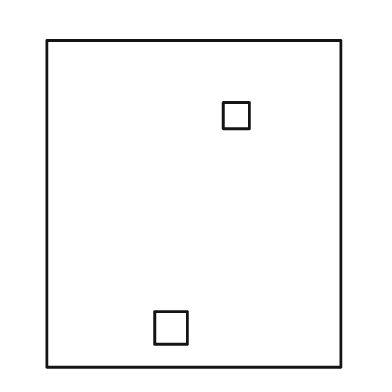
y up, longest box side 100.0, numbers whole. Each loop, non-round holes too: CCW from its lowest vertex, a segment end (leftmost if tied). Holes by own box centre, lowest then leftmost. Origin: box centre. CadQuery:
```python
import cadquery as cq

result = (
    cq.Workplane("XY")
    .moveTo(-45.0, -50.0)
    .lineTo(45.0, -50.0)
    .lineTo(45.0, 50.0)
    .lineTo(-45.0, 50.0)
    .close()
    .moveTo(-12.0, -43.0)
    .lineTo(-2.0, -43.0)
    .lineTo(-2.0, -33.0)
    .lineTo(-12.0, -33.0)
    .close()
    .moveTo(9.0, 23.0)
    .lineTo(17.0, 23.0)
    .lineTo(17.0, 31.0)
    .lineTo(9.0, 31.0)
    .close()
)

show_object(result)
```